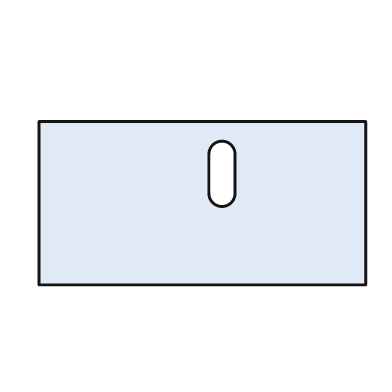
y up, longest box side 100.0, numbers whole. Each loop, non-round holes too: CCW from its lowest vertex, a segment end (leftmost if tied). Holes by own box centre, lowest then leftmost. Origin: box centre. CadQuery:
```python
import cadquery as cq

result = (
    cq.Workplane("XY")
    .moveTo(-50.0, -25.0)
    .lineTo(50.0, -25.0)
    .lineTo(50.0, 25.0)
    .lineTo(-50.0, 25.0)
    .close()
    .moveTo(2.0, 3.0)
    .threePointArc((6.0, -1.0), (10.0, 3.0))
    .lineTo(10.0, 15.0)
    .threePointArc((6.0, 19.0), (2.0, 15.0))
    .close()
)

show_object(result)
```